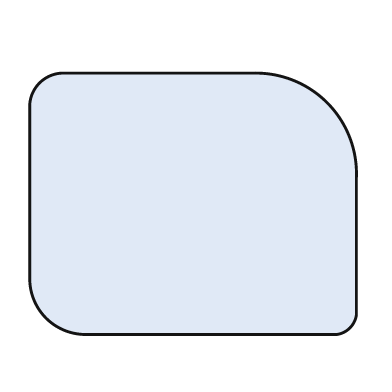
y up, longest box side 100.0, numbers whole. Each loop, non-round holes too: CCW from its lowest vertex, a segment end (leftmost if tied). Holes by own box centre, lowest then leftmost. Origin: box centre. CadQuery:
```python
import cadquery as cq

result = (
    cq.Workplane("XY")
    .moveTo(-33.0, -40.0)
    .lineTo(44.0, -40.0)
    .threePointArc((48.0, -38.0), (50.0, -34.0))
    .lineTo(50.0, 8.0)
    .threePointArc((41.0, 31.0), (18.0, 40.0))
    .lineTo(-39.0, 40.0)
    .threePointArc((-47.0, 37.0), (-50.0, 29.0))
    .lineTo(-50.0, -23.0)
    .threePointArc((-45.0, -35.0), (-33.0, -40.0))
    .close()
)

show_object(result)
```